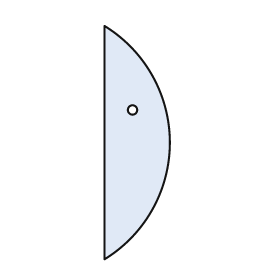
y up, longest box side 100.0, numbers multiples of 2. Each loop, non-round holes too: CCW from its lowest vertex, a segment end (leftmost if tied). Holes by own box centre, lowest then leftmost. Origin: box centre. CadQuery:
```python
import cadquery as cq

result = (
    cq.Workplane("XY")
    .moveTo(-14.0, -50.0)
    .threePointArc((14.0, 0.0), (-14.0, 50.0))
    .close()
    .moveTo(-2.0, 14.0)
    .circle(2.0)
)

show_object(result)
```